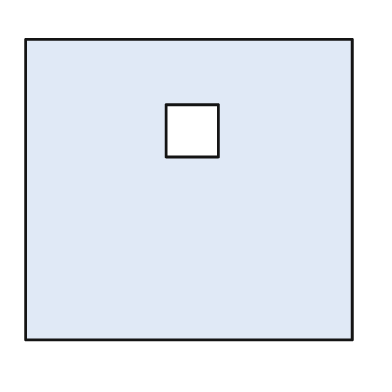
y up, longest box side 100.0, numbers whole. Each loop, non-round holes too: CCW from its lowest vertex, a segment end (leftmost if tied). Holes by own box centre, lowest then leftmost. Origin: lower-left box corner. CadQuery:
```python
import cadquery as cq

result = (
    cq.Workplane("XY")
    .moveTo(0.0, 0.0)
    .lineTo(100.0, 0.0)
    .lineTo(100.0, 92.0)
    .lineTo(0.0, 92.0)
    .close()
    .moveTo(43.0, 56.0)
    .lineTo(59.0, 56.0)
    .lineTo(59.0, 72.0)
    .lineTo(43.0, 72.0)
    .close()
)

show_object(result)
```